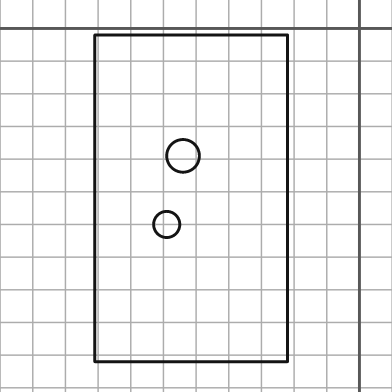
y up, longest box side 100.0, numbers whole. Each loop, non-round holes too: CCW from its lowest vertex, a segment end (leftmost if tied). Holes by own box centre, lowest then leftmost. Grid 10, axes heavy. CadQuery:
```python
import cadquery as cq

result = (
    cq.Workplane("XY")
    .moveTo(-81.0, -102.0)
    .lineTo(-22.0, -102.0)
    .lineTo(-22.0, -2.0)
    .lineTo(-81.0, -2.0)
    .close()
    .moveTo(-59.0, -60.0)
    .circle(4.0)
    .moveTo(-54.0, -39.0)
    .circle(5.0)
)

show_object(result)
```